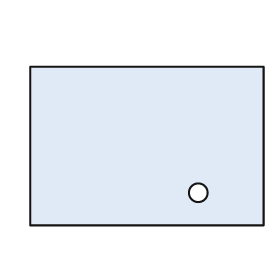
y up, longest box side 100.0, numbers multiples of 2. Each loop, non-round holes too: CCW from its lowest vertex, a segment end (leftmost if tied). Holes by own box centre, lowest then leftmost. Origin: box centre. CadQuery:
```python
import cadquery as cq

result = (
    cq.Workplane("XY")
    .moveTo(-50.0, -34.0)
    .lineTo(50.0, -34.0)
    .lineTo(50.0, 34.0)
    .lineTo(-50.0, 34.0)
    .close()
    .moveTo(22.0, -20.0)
    .circle(4.0)
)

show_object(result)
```